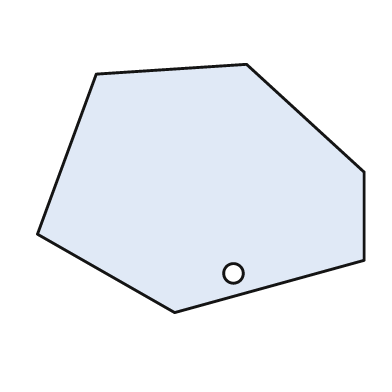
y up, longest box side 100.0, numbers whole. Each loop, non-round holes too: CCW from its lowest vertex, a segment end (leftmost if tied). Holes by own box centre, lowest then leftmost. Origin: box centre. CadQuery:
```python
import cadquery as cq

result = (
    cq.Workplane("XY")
    .moveTo(-8.0, -38.0)
    .lineTo(50.0, -22.0)
    .lineTo(50.0, 5.0)
    .lineTo(14.0, 38.0)
    .lineTo(-32.0, 35.0)
    .lineTo(-50.0, -14.0)
    .close()
    .moveTo(10.0, -26.0)
    .circle(3.0)
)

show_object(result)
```